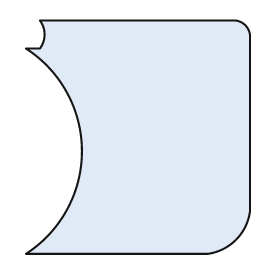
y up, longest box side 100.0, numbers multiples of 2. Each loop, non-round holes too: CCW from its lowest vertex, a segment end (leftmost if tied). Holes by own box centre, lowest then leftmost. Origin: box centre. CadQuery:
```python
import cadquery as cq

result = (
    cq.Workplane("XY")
    .moveTo(-48.0, -50.0)
    .lineTo(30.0, -50.0)
    .threePointArc((42.0, -44.0), (48.0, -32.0))
    .lineTo(48.0, 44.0)
    .threePointArc((46.0, 48.0), (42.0, 50.0))
    .lineTo(-42.0, 50.0)
    .threePointArc((-40.0, 44.0), (-42.0, 38.0))
    .lineTo(-48.0, 38.0)
    .threePointArc((-24.0, -6.0), (-48.0, -50.0))
    .close()
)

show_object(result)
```